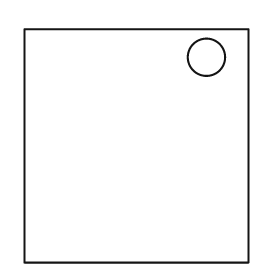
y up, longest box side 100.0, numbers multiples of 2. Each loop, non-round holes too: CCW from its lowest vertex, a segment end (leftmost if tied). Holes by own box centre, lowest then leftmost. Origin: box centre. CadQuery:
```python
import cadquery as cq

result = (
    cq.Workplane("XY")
    .moveTo(-48.0, -50.0)
    .lineTo(48.0, -50.0)
    .lineTo(48.0, 50.0)
    .lineTo(-48.0, 50.0)
    .close()
    .moveTo(30.0, 38.0)
    .circle(8.0)
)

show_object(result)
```